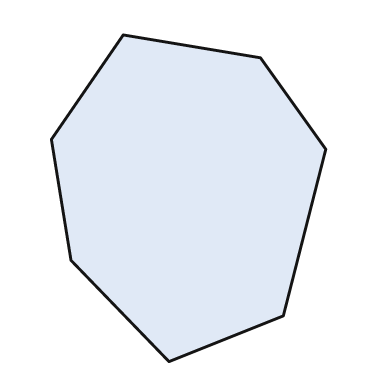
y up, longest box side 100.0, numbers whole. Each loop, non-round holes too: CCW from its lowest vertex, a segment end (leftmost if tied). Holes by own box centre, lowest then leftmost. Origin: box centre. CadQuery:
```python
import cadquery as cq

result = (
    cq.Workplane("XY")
    .moveTo(-6.0, -50.0)
    .lineTo(29.0, -36.0)
    .lineTo(42.0, 15.0)
    .lineTo(22.0, 43.0)
    .lineTo(-20.0, 50.0)
    .lineTo(-42.0, 18.0)
    .lineTo(-36.0, -19.0)
    .close()
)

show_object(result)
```